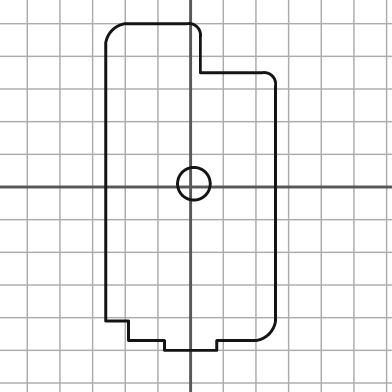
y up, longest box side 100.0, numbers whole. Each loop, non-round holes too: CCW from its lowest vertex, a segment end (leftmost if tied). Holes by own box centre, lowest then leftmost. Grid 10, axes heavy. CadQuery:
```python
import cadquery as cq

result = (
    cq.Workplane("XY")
    .moveTo(-8.0, -50.0)
    .lineTo(8.0, -50.0)
    .lineTo(8.0, -47.0)
    .lineTo(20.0, -47.0)
    .threePointArc((24.0, -45.0), (26.0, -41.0))
    .lineTo(26.0, 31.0)
    .threePointArc((25.0, 34.0), (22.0, 35.0))
    .lineTo(3.0, 35.0)
    .lineTo(3.0, 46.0)
    .threePointArc((2.0, 49.0), (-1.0, 50.0))
    .lineTo(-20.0, 50.0)
    .threePointArc((-24.0, 48.0), (-26.0, 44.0))
    .lineTo(-26.0, -41.0)
    .lineTo(-19.0, -41.0)
    .lineTo(-19.0, -47.0)
    .lineTo(-8.0, -47.0)
    .close()
    .moveTo(1.0, 1.0)
    .circle(5.0)
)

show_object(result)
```